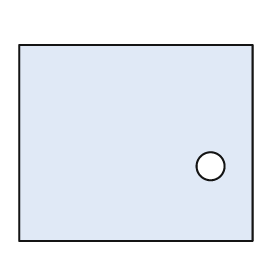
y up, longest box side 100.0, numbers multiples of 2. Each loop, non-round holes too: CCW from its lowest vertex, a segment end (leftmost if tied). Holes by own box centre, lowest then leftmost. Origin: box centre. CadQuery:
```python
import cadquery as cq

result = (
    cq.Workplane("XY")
    .moveTo(-50.0, -42.0)
    .lineTo(50.0, -42.0)
    .lineTo(50.0, 42.0)
    .lineTo(-50.0, 42.0)
    .close()
    .moveTo(32.0, -10.0)
    .circle(6.0)
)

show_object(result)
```